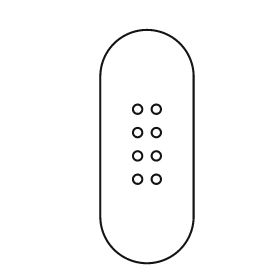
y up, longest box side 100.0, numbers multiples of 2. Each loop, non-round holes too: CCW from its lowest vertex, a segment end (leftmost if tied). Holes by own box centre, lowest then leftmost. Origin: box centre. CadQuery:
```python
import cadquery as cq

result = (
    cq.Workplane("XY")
    .moveTo(-20.0, -30.0)
    .threePointArc((0.0, -50.0), (20.0, -30.0))
    .lineTo(20.0, 30.0)
    .threePointArc((0.0, 50.0), (-20.0, 30.0))
    .close()
    .moveTo(-4.0, -14.0)
    .circle(2.0)
    .moveTo(4.0, -14.0)
    .circle(2.0)
    .moveTo(-4.0, -4.0)
    .circle(2.0)
    .moveTo(4.0, -4.0)
    .circle(2.0)
    .moveTo(-4.0, 6.0)
    .circle(2.0)
    .moveTo(4.0, 6.0)
    .circle(2.0)
    .moveTo(-4.0, 16.0)
    .circle(2.0)
    .moveTo(4.0, 16.0)
    .circle(2.0)
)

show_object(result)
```